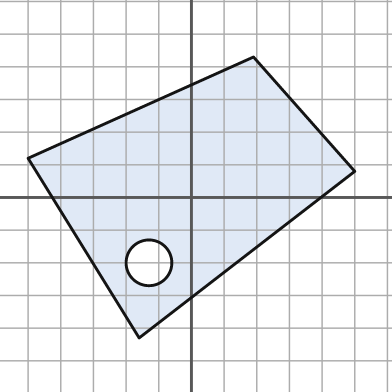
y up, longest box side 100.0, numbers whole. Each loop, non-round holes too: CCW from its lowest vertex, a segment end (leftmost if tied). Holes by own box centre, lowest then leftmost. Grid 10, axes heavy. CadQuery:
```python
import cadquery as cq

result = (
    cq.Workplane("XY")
    .moveTo(-16.0, -43.0)
    .lineTo(50.0, 8.0)
    .lineTo(19.0, 43.0)
    .lineTo(-50.0, 12.0)
    .close()
    .moveTo(-13.0, -20.0)
    .circle(7.0)
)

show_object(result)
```